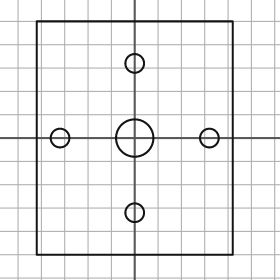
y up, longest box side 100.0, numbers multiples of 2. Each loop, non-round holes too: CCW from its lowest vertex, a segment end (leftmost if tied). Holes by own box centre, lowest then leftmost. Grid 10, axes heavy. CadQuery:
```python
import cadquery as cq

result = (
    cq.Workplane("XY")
    .moveTo(-42.0, -50.0)
    .lineTo(42.0, -50.0)
    .lineTo(42.0, 50.0)
    .lineTo(-42.0, 50.0)
    .close()
    .moveTo(0.0, -32.0)
    .circle(4.0)
    .moveTo(-32.0, 0.0)
    .circle(4.0)
    .moveTo(0.0, 0.0)
    .circle(8.0)
    .moveTo(32.0, 0.0)
    .circle(4.0)
    .moveTo(0.0, 32.0)
    .circle(4.0)
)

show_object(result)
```